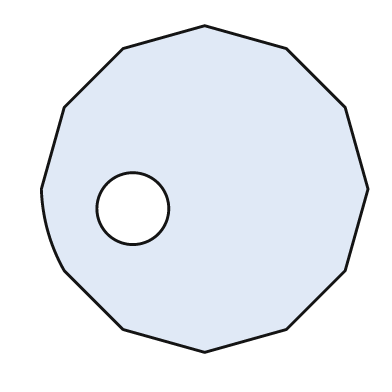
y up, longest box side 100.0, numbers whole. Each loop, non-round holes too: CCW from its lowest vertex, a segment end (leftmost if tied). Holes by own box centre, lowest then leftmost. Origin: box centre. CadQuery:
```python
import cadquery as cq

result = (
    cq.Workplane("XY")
    .moveTo(0.0, -50.0)
    .lineTo(25.0, -43.0)
    .lineTo(43.0, -25.0)
    .lineTo(50.0, 0.0)
    .lineTo(43.0, 25.0)
    .lineTo(25.0, 43.0)
    .lineTo(0.0, 50.0)
    .lineTo(-25.0, 43.0)
    .lineTo(-43.0, 25.0)
    .lineTo(-50.0, 0.0)
    .threePointArc((-48.0, -13.0), (-43.0, -25.0))
    .lineTo(-25.0, -43.0)
    .close()
    .moveTo(-22.0, -6.0)
    .circle(11.0)
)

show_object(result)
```